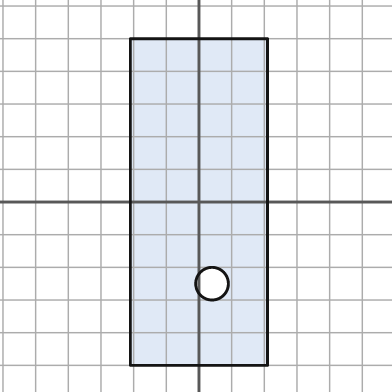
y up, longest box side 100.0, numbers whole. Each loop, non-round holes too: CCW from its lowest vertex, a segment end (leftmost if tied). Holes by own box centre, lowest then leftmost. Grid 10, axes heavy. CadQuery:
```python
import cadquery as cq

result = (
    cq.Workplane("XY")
    .moveTo(-21.0, -50.0)
    .lineTo(21.0, -50.0)
    .lineTo(21.0, 50.0)
    .lineTo(-21.0, 50.0)
    .close()
    .moveTo(4.0, -25.0)
    .circle(5.0)
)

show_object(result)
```